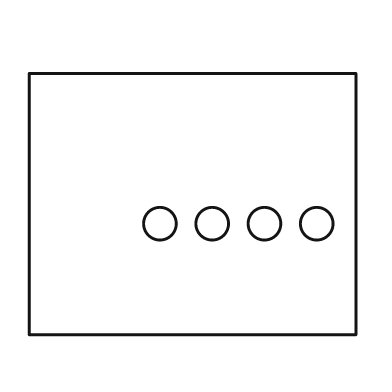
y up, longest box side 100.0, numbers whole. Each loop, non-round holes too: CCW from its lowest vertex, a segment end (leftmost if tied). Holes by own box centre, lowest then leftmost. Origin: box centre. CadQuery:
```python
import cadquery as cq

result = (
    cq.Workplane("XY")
    .moveTo(-50.0, -40.0)
    .lineTo(50.0, -40.0)
    .lineTo(50.0, 40.0)
    .lineTo(-50.0, 40.0)
    .close()
    .moveTo(-10.0, -6.0)
    .circle(5.0)
    .moveTo(6.0, -6.0)
    .circle(5.0)
    .moveTo(22.0, -6.0)
    .circle(5.0)
    .moveTo(38.0, -6.0)
    .circle(5.0)
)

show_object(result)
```